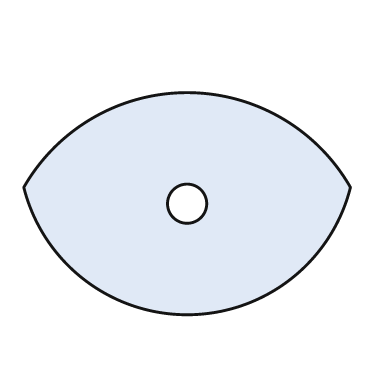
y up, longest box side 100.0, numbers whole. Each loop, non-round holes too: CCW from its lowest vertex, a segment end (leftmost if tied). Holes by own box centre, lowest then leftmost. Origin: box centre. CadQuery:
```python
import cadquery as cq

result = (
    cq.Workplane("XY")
    .moveTo(-50.0, 5.0)
    .threePointArc((0.0, -34.0), (50.0, 5.0))
    .threePointArc((0.0, 34.0), (-50.0, 5.0))
    .close()
    .moveTo(0.0, 0.0)
    .circle(6.0)
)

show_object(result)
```